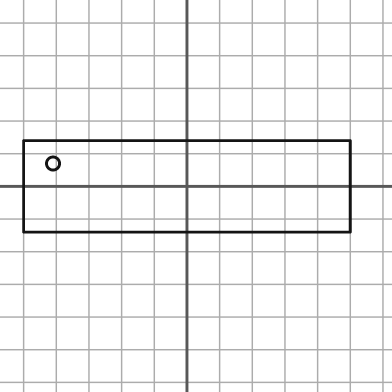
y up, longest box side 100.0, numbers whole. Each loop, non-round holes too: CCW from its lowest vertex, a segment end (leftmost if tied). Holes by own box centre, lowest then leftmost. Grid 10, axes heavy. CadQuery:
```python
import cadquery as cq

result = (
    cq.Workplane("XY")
    .moveTo(-50.0, -14.0)
    .lineTo(50.0, -14.0)
    .lineTo(50.0, 14.0)
    .lineTo(-50.0, 14.0)
    .close()
    .moveTo(-41.0, 7.0)
    .circle(2.0)
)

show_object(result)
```